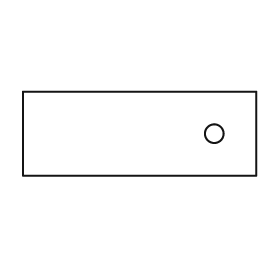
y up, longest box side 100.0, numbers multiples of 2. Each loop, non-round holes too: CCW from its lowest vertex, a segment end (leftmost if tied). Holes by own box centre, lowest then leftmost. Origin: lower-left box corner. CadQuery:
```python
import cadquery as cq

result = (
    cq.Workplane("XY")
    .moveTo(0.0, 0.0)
    .lineTo(100.0, 0.0)
    .lineTo(100.0, 36.0)
    .lineTo(0.0, 36.0)
    .close()
    .moveTo(82.0, 18.0)
    .circle(4.0)
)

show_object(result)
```